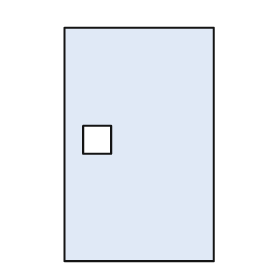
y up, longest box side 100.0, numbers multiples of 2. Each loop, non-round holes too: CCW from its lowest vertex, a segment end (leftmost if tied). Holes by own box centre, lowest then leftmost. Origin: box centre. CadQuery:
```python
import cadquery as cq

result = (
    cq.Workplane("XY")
    .moveTo(-32.0, -50.0)
    .lineTo(32.0, -50.0)
    .lineTo(32.0, 50.0)
    .lineTo(-32.0, 50.0)
    .close()
    .moveTo(-24.0, -4.0)
    .lineTo(-12.0, -4.0)
    .lineTo(-12.0, 8.0)
    .lineTo(-24.0, 8.0)
    .close()
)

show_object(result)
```